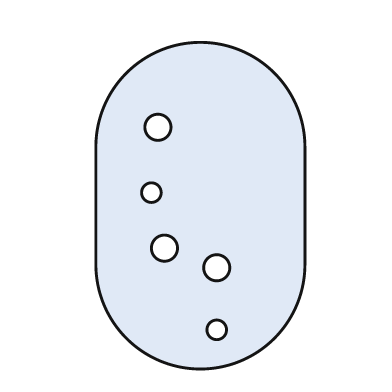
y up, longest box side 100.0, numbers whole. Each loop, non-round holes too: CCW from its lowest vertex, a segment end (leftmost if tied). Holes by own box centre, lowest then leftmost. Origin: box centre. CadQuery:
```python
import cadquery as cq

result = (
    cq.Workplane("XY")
    .moveTo(-32.0, -18.0)
    .threePointArc((0.0, -50.0), (32.0, -18.0))
    .lineTo(32.0, 18.0)
    .threePointArc((0.0, 50.0), (-32.0, 18.0))
    .close()
    .moveTo(5.0, -38.0)
    .circle(3.0)
    .moveTo(5.0, -19.0)
    .circle(4.0)
    .moveTo(-11.0, -13.0)
    .circle(4.0)
    .moveTo(-15.0, 4.0)
    .circle(3.0)
    .moveTo(-13.0, 24.0)
    .circle(4.0)
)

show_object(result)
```